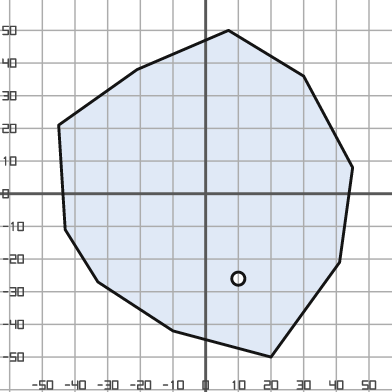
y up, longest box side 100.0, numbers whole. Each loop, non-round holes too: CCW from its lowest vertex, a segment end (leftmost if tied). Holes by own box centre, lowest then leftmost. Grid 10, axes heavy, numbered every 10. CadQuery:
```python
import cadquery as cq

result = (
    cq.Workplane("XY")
    .moveTo(20.0, -50.0)
    .lineTo(41.0, -21.0)
    .lineTo(45.0, 8.0)
    .lineTo(30.0, 36.0)
    .lineTo(7.0, 50.0)
    .lineTo(-21.0, 38.0)
    .lineTo(-45.0, 21.0)
    .lineTo(-43.0, -11.0)
    .lineTo(-33.0, -27.0)
    .lineTo(-10.0, -42.0)
    .close()
    .moveTo(10.0, -26.0)
    .circle(2.0)
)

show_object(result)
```